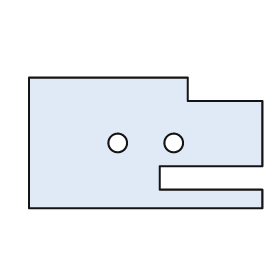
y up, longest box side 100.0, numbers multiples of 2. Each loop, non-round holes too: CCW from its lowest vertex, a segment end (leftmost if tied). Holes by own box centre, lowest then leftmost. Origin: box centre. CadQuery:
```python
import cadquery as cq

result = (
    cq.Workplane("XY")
    .moveTo(-50.0, -28.0)
    .lineTo(50.0, -28.0)
    .lineTo(50.0, -20.0)
    .lineTo(6.0, -20.0)
    .lineTo(6.0, -10.0)
    .lineTo(50.0, -10.0)
    .lineTo(50.0, 18.0)
    .lineTo(18.0, 18.0)
    .lineTo(18.0, 28.0)
    .lineTo(-50.0, 28.0)
    .close()
    .moveTo(-12.0, 0.0)
    .circle(4.0)
    .moveTo(12.0, 0.0)
    .circle(4.0)
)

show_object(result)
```